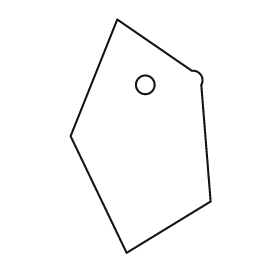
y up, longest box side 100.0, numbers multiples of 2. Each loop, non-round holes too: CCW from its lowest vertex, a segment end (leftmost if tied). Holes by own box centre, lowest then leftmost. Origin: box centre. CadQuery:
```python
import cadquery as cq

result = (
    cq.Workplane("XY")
    .moveTo(-6.0, -50.0)
    .lineTo(30.0, -28.0)
    .lineTo(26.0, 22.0)
    .threePointArc((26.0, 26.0), (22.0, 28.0))
    .lineTo(-10.0, 50.0)
    .lineTo(-30.0, 0.0)
    .close()
    .moveTo(2.0, 22.0)
    .circle(4.0)
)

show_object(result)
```